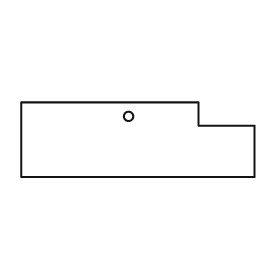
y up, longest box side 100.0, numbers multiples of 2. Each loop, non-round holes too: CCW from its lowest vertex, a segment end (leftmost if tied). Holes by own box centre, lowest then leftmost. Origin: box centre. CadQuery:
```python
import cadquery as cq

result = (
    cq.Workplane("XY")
    .moveTo(-50.0, -16.0)
    .lineTo(50.0, -16.0)
    .lineTo(50.0, 6.0)
    .lineTo(26.0, 6.0)
    .lineTo(26.0, 16.0)
    .lineTo(-50.0, 16.0)
    .close()
    .moveTo(-4.0, 10.0)
    .circle(2.0)
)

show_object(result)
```